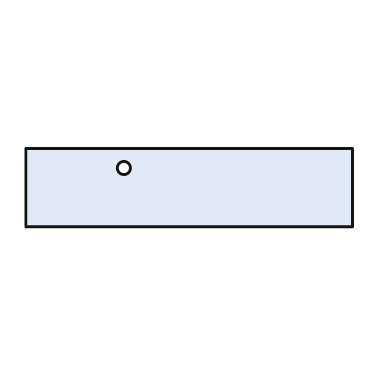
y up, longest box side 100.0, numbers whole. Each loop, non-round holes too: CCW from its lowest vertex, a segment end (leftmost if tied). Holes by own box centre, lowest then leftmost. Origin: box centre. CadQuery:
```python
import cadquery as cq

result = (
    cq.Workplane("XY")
    .moveTo(-50.0, -12.0)
    .lineTo(50.0, -12.0)
    .lineTo(50.0, 12.0)
    .lineTo(-50.0, 12.0)
    .close()
    .moveTo(-20.0, 6.0)
    .circle(2.0)
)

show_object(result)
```